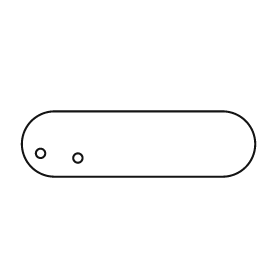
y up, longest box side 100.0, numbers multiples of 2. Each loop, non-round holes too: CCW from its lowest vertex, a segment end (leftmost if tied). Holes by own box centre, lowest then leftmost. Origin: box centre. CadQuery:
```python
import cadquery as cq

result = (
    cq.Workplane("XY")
    .moveTo(-36.0, -14.0)
    .lineTo(36.0, -14.0)
    .threePointArc((50.0, 0.0), (36.0, 14.0))
    .lineTo(-36.0, 14.0)
    .threePointArc((-50.0, 0.0), (-36.0, -14.0))
    .close()
    .moveTo(-26.0, -6.0)
    .circle(2.0)
    .moveTo(-42.0, -4.0)
    .circle(2.0)
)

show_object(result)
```